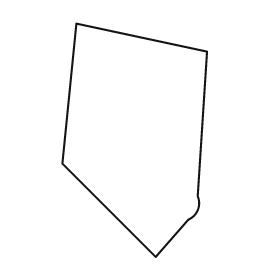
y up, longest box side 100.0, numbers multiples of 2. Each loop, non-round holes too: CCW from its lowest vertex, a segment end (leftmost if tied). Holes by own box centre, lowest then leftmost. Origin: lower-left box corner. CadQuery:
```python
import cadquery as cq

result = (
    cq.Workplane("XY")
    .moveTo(40.0, 0.0)
    .lineTo(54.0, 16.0)
    .threePointArc((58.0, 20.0), (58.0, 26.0))
    .lineTo(62.0, 88.0)
    .lineTo(6.0, 100.0)
    .lineTo(0.0, 40.0)
    .close()
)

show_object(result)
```